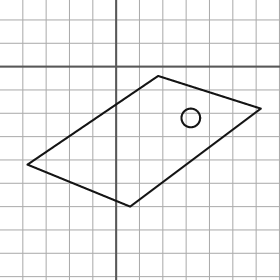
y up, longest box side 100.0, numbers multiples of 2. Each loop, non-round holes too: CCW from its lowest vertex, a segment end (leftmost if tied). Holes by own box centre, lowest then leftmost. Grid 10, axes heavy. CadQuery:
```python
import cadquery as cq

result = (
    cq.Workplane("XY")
    .moveTo(6.0, -60.0)
    .lineTo(62.0, -18.0)
    .lineTo(18.0, -4.0)
    .lineTo(-38.0, -42.0)
    .close()
    .moveTo(32.0, -22.0)
    .circle(4.0)
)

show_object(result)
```